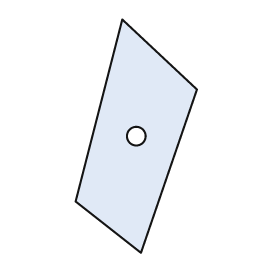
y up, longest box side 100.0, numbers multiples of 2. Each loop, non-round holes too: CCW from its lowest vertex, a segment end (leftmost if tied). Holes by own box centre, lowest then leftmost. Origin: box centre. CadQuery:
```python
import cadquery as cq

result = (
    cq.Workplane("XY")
    .moveTo(2.0, -50.0)
    .lineTo(26.0, 20.0)
    .lineTo(-6.0, 50.0)
    .lineTo(-26.0, -28.0)
    .close()
    .moveTo(0.0, 0.0)
    .circle(4.0)
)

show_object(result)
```